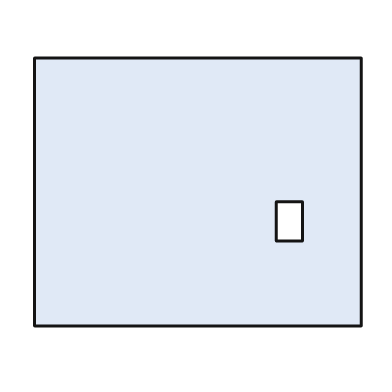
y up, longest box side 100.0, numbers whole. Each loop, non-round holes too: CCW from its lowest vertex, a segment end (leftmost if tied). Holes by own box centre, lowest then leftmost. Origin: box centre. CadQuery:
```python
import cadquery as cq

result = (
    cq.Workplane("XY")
    .moveTo(-50.0, -41.0)
    .lineTo(50.0, -41.0)
    .lineTo(50.0, 41.0)
    .lineTo(-50.0, 41.0)
    .close()
    .moveTo(24.0, -15.0)
    .lineTo(32.0, -15.0)
    .lineTo(32.0, -3.0)
    .lineTo(24.0, -3.0)
    .close()
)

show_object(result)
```